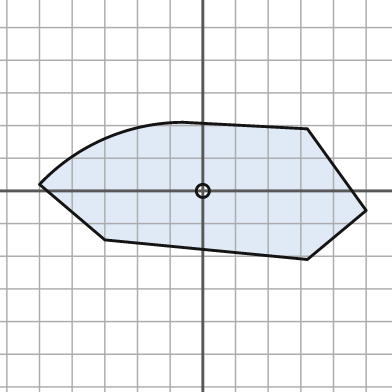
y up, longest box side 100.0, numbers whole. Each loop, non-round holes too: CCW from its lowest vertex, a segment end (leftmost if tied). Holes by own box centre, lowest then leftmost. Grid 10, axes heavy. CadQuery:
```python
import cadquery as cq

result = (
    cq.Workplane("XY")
    .moveTo(32.0, -21.0)
    .lineTo(50.0, -6.0)
    .lineTo(32.0, 19.0)
    .lineTo(-6.0, 21.0)
    .threePointArc((-30.0, 16.0), (-50.0, 2.0))
    .lineTo(-30.0, -15.0)
    .close()
    .moveTo(0.0, 0.0)
    .circle(2.0)
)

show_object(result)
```